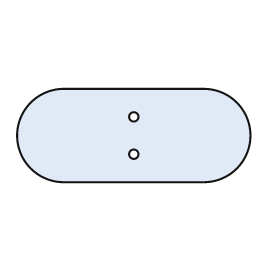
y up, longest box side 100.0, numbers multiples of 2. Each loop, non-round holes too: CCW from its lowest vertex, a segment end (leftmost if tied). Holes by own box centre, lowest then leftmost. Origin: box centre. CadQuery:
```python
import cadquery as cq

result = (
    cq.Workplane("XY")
    .moveTo(-30.0, -20.0)
    .lineTo(30.0, -20.0)
    .threePointArc((50.0, 0.0), (30.0, 20.0))
    .lineTo(-30.0, 20.0)
    .threePointArc((-50.0, 0.0), (-30.0, -20.0))
    .close()
    .moveTo(0.0, -8.0)
    .circle(2.0)
    .moveTo(0.0, 8.0)
    .circle(2.0)
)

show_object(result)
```